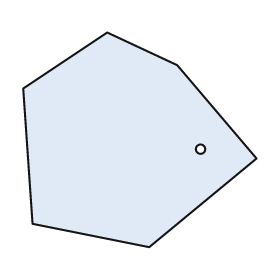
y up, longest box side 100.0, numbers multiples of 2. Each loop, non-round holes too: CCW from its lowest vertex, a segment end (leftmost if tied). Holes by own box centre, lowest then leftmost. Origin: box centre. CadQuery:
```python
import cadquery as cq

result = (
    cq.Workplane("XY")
    .moveTo(4.0, -46.0)
    .lineTo(50.0, -8.0)
    .lineTo(16.0, 32.0)
    .lineTo(-14.0, 46.0)
    .lineTo(-50.0, 22.0)
    .lineTo(-46.0, -36.0)
    .close()
    .moveTo(26.0, -4.0)
    .circle(2.0)
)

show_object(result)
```